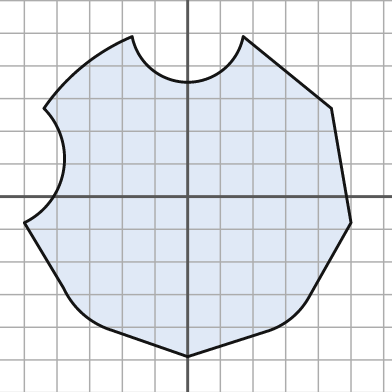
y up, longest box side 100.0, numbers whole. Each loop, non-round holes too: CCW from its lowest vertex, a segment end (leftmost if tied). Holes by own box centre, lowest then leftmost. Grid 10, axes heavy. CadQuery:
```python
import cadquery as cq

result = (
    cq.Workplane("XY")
    .moveTo(0.0, -49.0)
    .lineTo(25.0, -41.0)
    .threePointArc((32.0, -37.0), (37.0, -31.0))
    .lineTo(50.0, -8.0)
    .lineTo(44.0, 27.0)
    .lineTo(17.0, 49.0)
    .threePointArc((0.0, 35.0), (-17.0, 49.0))
    .threePointArc((-32.0, 40.0), (-44.0, 27.0))
    .threePointArc((-38.0, 8.0), (-50.0, -8.0))
    .lineTo(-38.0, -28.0)
    .threePointArc((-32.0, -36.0), (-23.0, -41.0))
    .close()
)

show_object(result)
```